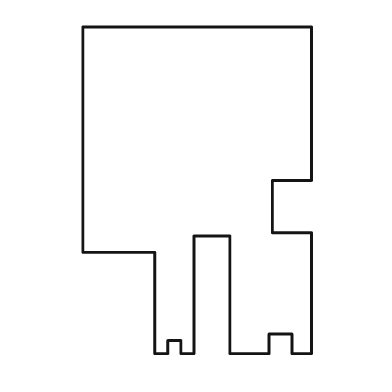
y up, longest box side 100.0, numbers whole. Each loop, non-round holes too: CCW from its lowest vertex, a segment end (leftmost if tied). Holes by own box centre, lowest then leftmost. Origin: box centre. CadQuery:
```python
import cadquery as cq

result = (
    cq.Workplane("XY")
    .moveTo(-13.0, -50.0)
    .lineTo(-9.0, -50.0)
    .lineTo(-9.0, -46.0)
    .lineTo(-5.0, -46.0)
    .lineTo(-5.0, -50.0)
    .lineTo(-1.0, -50.0)
    .lineTo(-1.0, -14.0)
    .lineTo(10.0, -14.0)
    .lineTo(10.0, -50.0)
    .lineTo(22.0, -50.0)
    .lineTo(22.0, -44.0)
    .lineTo(29.0, -44.0)
    .lineTo(29.0, -50.0)
    .lineTo(35.0, -50.0)
    .lineTo(35.0, -13.0)
    .lineTo(23.0, -13.0)
    .lineTo(23.0, 3.0)
    .lineTo(35.0, 3.0)
    .lineTo(35.0, 50.0)
    .lineTo(-35.0, 50.0)
    .lineTo(-35.0, -19.0)
    .lineTo(-13.0, -19.0)
    .close()
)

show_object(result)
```